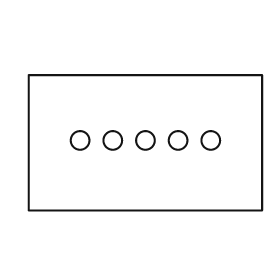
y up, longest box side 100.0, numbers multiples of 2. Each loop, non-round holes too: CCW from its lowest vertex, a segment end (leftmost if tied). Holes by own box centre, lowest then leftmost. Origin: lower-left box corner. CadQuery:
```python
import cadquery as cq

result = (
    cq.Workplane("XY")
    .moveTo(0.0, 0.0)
    .lineTo(100.0, 0.0)
    .lineTo(100.0, 58.0)
    .lineTo(0.0, 58.0)
    .close()
    .moveTo(22.0, 30.0)
    .circle(4.0)
    .moveTo(36.0, 30.0)
    .circle(4.0)
    .moveTo(50.0, 30.0)
    .circle(4.0)
    .moveTo(64.0, 30.0)
    .circle(4.0)
    .moveTo(78.0, 30.0)
    .circle(4.0)
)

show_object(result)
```